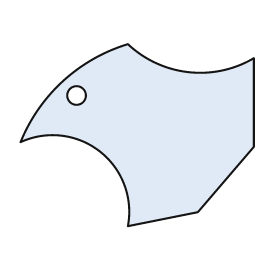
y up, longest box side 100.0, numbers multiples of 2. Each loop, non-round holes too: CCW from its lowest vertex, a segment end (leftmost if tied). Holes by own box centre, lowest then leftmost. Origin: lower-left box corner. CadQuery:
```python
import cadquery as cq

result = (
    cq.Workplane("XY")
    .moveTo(46.0, 0.0)
    .lineTo(76.0, 6.0)
    .lineTo(100.0, 34.0)
    .lineTo(100.0, 72.0)
    .threePointArc((72.0, 66.0), (46.0, 78.0))
    .threePointArc((18.0, 62.0), (0.0, 36.0))
    .threePointArc((34.0, 32.0), (46.0, 0.0))
    .close()
    .moveTo(24.0, 56.0)
    .circle(4.0)
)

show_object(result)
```